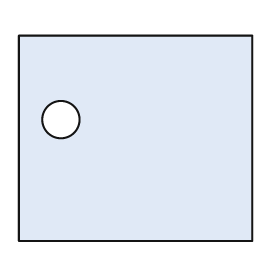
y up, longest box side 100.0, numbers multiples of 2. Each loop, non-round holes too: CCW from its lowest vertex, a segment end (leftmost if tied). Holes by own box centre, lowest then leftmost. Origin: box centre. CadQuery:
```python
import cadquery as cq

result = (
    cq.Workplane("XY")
    .moveTo(-50.0, -44.0)
    .lineTo(50.0, -44.0)
    .lineTo(50.0, 44.0)
    .lineTo(-50.0, 44.0)
    .close()
    .moveTo(-32.0, 8.0)
    .circle(8.0)
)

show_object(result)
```